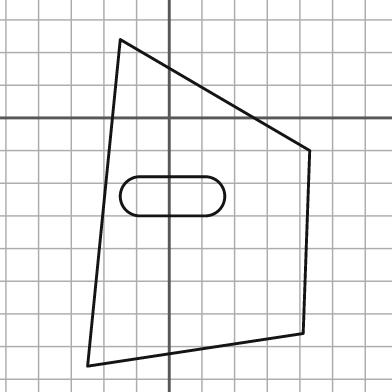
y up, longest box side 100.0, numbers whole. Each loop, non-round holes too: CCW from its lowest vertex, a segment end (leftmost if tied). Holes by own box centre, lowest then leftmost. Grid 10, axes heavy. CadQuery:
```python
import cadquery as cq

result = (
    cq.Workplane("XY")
    .moveTo(-25.0, -76.0)
    .lineTo(41.0, -66.0)
    .lineTo(43.0, -10.0)
    .lineTo(-15.0, 24.0)
    .close()
    .moveTo(-9.0, -30.0)
    .lineTo(11.0, -30.0)
    .threePointArc((17.0, -24.0), (11.0, -18.0))
    .lineTo(-9.0, -18.0)
    .threePointArc((-15.0, -24.0), (-9.0, -30.0))
    .close()
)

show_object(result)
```